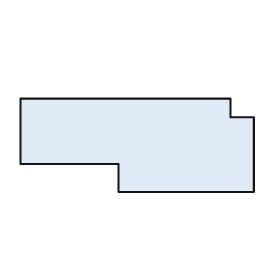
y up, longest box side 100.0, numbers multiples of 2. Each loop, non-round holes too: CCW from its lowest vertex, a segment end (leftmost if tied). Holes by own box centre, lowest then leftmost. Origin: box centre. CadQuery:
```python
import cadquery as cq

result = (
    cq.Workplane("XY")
    .moveTo(-8.0, -20.0)
    .lineTo(50.0, -20.0)
    .lineTo(50.0, 12.0)
    .lineTo(40.0, 12.0)
    .lineTo(40.0, 20.0)
    .lineTo(-50.0, 20.0)
    .lineTo(-50.0, -8.0)
    .lineTo(-8.0, -8.0)
    .close()
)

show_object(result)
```